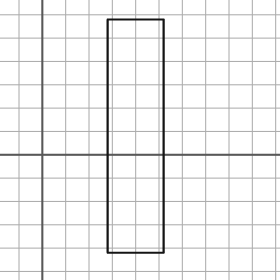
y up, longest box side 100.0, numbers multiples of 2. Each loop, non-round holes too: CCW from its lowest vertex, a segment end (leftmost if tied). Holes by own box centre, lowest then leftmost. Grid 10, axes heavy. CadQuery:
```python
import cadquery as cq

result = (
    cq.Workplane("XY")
    .moveTo(28.0, -42.0)
    .lineTo(52.0, -42.0)
    .lineTo(52.0, 58.0)
    .lineTo(28.0, 58.0)
    .close()
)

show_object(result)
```